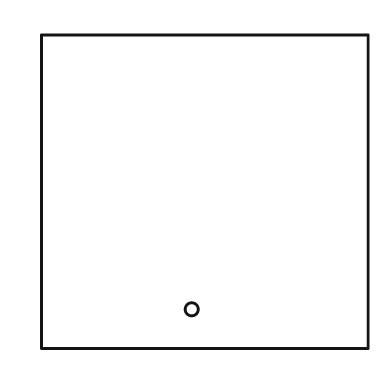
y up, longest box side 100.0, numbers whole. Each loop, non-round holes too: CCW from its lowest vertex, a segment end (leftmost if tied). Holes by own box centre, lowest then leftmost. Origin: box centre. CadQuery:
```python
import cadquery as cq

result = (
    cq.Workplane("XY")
    .moveTo(-50.0, -48.0)
    .lineTo(50.0, -48.0)
    .lineTo(50.0, 48.0)
    .lineTo(-50.0, 48.0)
    .close()
    .moveTo(-4.0, -36.0)
    .circle(2.0)
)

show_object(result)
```